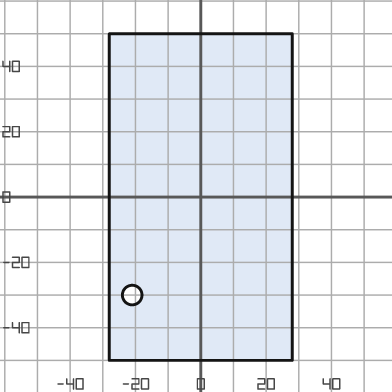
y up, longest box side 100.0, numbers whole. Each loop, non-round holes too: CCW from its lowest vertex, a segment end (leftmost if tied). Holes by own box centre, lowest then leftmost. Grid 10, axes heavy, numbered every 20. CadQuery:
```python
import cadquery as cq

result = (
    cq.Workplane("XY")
    .moveTo(-28.0, -50.0)
    .lineTo(28.0, -50.0)
    .lineTo(28.0, 50.0)
    .lineTo(-28.0, 50.0)
    .close()
    .moveTo(-21.0, -30.0)
    .circle(3.0)
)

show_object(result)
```